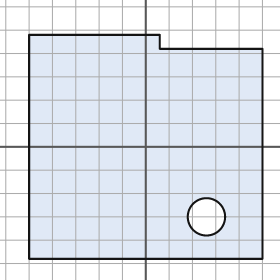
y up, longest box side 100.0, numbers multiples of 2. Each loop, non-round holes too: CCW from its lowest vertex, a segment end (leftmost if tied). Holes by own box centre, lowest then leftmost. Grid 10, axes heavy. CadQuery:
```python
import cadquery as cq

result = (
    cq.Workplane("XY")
    .moveTo(-50.0, -48.0)
    .lineTo(50.0, -48.0)
    .lineTo(50.0, 42.0)
    .lineTo(6.0, 42.0)
    .lineTo(6.0, 48.0)
    .lineTo(-50.0, 48.0)
    .close()
    .moveTo(26.0, -30.0)
    .circle(8.0)
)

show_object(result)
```